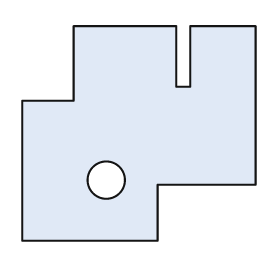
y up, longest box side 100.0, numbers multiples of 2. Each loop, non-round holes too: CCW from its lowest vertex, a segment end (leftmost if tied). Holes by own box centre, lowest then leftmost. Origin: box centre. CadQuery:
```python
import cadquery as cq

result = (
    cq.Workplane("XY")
    .moveTo(-50.0, -46.0)
    .lineTo(8.0, -46.0)
    .lineTo(8.0, -22.0)
    .lineTo(50.0, -22.0)
    .lineTo(50.0, 46.0)
    .lineTo(22.0, 46.0)
    .lineTo(22.0, 20.0)
    .lineTo(16.0, 20.0)
    .lineTo(16.0, 46.0)
    .lineTo(-28.0, 46.0)
    .lineTo(-28.0, 14.0)
    .lineTo(-50.0, 14.0)
    .close()
    .moveTo(-14.0, -20.0)
    .circle(8.0)
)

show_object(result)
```